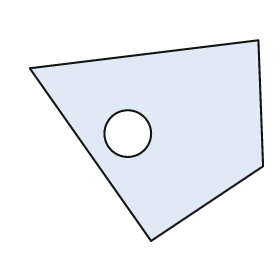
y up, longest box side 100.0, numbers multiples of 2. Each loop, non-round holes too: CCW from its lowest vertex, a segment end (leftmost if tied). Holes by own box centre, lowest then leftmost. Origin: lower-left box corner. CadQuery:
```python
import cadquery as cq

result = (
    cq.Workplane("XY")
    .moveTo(52.0, 0.0)
    .lineTo(100.0, 32.0)
    .lineTo(98.0, 86.0)
    .lineTo(0.0, 74.0)
    .close()
    .moveTo(42.0, 46.0)
    .circle(10.0)
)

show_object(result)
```